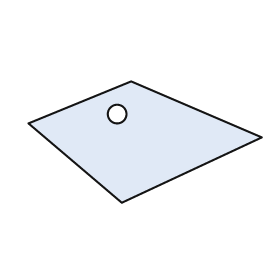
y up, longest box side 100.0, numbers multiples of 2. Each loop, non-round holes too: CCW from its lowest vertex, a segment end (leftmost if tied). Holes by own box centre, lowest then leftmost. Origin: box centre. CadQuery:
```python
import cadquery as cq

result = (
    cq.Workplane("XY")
    .moveTo(-10.0, -26.0)
    .lineTo(50.0, 2.0)
    .lineTo(-6.0, 26.0)
    .lineTo(-50.0, 8.0)
    .close()
    .moveTo(-12.0, 12.0)
    .circle(4.0)
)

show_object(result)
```